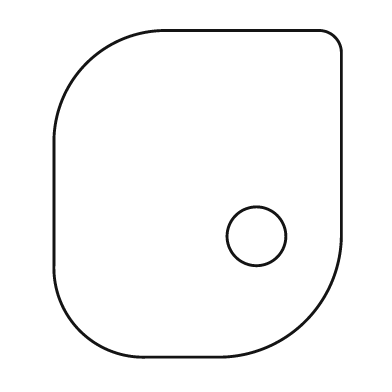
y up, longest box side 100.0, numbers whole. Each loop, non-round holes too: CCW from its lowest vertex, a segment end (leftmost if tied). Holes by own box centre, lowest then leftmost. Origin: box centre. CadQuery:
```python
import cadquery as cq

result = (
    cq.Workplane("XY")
    .moveTo(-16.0, -50.0)
    .lineTo(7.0, -50.0)
    .threePointArc((33.0, -39.0), (44.0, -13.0))
    .lineTo(44.0, 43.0)
    .threePointArc((42.0, 48.0), (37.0, 50.0))
    .lineTo(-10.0, 50.0)
    .threePointArc((-34.0, 40.0), (-44.0, 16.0))
    .lineTo(-44.0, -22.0)
    .threePointArc((-36.0, -42.0), (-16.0, -50.0))
    .close()
    .moveTo(18.0, -13.0)
    .circle(9.0)
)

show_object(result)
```